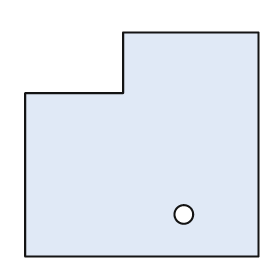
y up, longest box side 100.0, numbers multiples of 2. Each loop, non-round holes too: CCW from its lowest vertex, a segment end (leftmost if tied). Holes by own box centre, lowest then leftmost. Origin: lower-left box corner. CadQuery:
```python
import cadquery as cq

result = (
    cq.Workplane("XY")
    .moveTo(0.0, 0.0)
    .lineTo(100.0, 0.0)
    .lineTo(100.0, 96.0)
    .lineTo(42.0, 96.0)
    .lineTo(42.0, 70.0)
    .lineTo(0.0, 70.0)
    .close()
    .moveTo(68.0, 18.0)
    .circle(4.0)
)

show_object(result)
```